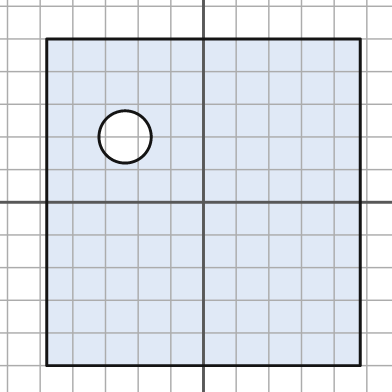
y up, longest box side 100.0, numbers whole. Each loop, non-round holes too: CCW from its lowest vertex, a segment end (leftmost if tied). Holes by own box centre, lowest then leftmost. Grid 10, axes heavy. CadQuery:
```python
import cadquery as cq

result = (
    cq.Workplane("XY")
    .moveTo(-48.0, -50.0)
    .lineTo(48.0, -50.0)
    .lineTo(48.0, 50.0)
    .lineTo(-48.0, 50.0)
    .close()
    .moveTo(-24.0, 20.0)
    .circle(8.0)
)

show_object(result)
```